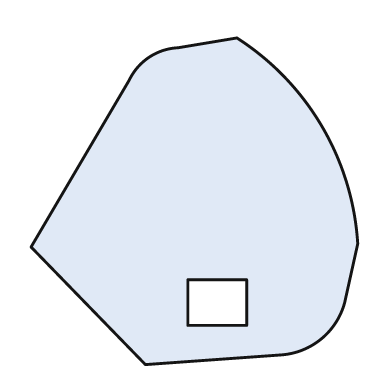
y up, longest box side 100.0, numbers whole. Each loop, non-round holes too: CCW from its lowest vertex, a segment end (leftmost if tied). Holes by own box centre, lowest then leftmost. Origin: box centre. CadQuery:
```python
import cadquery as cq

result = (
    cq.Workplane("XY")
    .moveTo(-15.0, -50.0)
    .lineTo(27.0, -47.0)
    .threePointArc((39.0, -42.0), (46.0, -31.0))
    .lineTo(50.0, -13.0)
    .threePointArc((39.0, 23.0), (13.0, 50.0))
    .lineTo(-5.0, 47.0)
    .threePointArc((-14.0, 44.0), (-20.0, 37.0))
    .lineTo(-50.0, -14.0)
    .close()
    .moveTo(-2.0, -38.0)
    .lineTo(16.0, -38.0)
    .lineTo(16.0, -24.0)
    .lineTo(-2.0, -24.0)
    .close()
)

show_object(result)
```